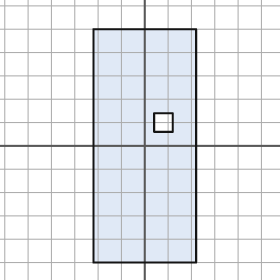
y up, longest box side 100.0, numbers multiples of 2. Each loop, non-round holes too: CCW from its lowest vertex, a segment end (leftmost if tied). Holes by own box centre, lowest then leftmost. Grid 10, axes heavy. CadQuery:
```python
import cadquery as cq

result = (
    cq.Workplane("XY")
    .moveTo(-22.0, -50.0)
    .lineTo(22.0, -50.0)
    .lineTo(22.0, 50.0)
    .lineTo(-22.0, 50.0)
    .close()
    .moveTo(4.0, 6.0)
    .lineTo(12.0, 6.0)
    .lineTo(12.0, 14.0)
    .lineTo(4.0, 14.0)
    .close()
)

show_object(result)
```